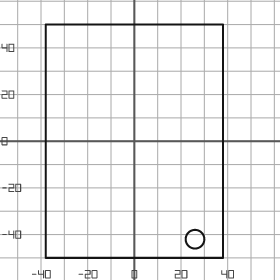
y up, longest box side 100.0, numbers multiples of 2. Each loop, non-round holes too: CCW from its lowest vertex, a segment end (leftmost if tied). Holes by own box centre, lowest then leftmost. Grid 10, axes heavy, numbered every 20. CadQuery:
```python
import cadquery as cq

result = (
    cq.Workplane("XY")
    .moveTo(-38.0, -50.0)
    .lineTo(38.0, -50.0)
    .lineTo(38.0, 50.0)
    .lineTo(-38.0, 50.0)
    .close()
    .moveTo(26.0, -42.0)
    .circle(4.0)
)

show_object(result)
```